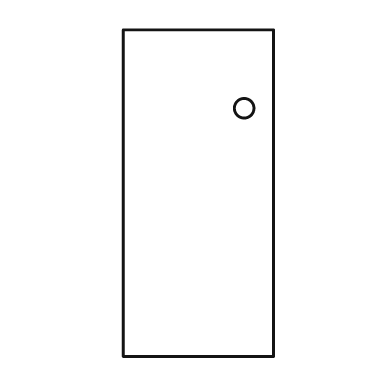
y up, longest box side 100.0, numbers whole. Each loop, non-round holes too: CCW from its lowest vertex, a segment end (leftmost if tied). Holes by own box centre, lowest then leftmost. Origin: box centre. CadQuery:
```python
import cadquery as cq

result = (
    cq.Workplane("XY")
    .moveTo(-23.0, -50.0)
    .lineTo(23.0, -50.0)
    .lineTo(23.0, 50.0)
    .lineTo(-23.0, 50.0)
    .close()
    .moveTo(14.0, 26.0)
    .circle(3.0)
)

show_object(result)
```